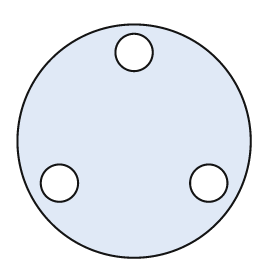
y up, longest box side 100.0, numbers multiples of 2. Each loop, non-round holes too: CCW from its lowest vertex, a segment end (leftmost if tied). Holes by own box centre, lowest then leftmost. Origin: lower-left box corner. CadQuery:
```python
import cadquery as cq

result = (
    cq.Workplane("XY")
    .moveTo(50.0, 50.0)
    .circle(50.0)
    .moveTo(18.0, 32.0)
    .circle(8.0)
    .moveTo(82.0, 32.0)
    .circle(8.0)
    .moveTo(50.0, 88.0)
    .circle(8.0)
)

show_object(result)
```